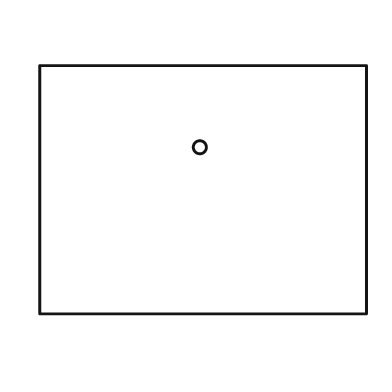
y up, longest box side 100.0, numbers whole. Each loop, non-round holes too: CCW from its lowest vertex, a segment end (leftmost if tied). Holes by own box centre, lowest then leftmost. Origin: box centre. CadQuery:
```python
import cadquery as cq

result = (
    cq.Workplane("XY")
    .moveTo(-50.0, -38.0)
    .lineTo(50.0, -38.0)
    .lineTo(50.0, 38.0)
    .lineTo(-50.0, 38.0)
    .close()
    .moveTo(-1.0, 13.0)
    .circle(2.0)
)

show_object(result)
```